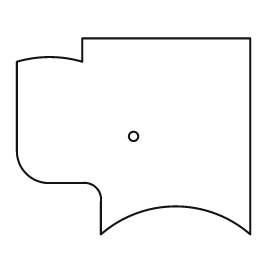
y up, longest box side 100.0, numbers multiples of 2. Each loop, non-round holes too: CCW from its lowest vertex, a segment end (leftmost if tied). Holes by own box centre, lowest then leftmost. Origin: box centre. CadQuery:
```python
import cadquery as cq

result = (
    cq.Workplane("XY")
    .moveTo(-14.0, -42.0)
    .threePointArc((18.0, -30.0), (50.0, -42.0))
    .lineTo(50.0, 42.0)
    .lineTo(-22.0, 42.0)
    .lineTo(-22.0, 32.0)
    .threePointArc((-36.0, 34.0), (-50.0, 32.0))
    .lineTo(-50.0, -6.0)
    .threePointArc((-46.0, -16.0), (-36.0, -20.0))
    .lineTo(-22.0, -20.0)
    .threePointArc((-16.0, -22.0), (-14.0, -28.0))
    .close()
    .moveTo(0.0, 0.0)
    .circle(2.0)
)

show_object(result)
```